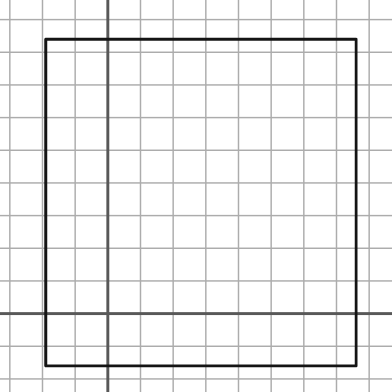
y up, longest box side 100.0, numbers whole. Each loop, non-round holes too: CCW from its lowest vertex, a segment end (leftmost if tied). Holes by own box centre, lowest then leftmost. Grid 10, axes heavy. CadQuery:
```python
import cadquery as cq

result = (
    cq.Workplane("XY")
    .moveTo(-19.0, -16.0)
    .lineTo(76.0, -16.0)
    .lineTo(76.0, 84.0)
    .lineTo(-19.0, 84.0)
    .close()
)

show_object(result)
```